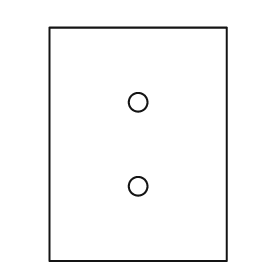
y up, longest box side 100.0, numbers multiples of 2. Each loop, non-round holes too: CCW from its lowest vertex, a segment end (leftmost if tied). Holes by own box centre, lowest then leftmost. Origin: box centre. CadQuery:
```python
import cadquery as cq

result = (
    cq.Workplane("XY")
    .moveTo(-38.0, -50.0)
    .lineTo(38.0, -50.0)
    .lineTo(38.0, 50.0)
    .lineTo(-38.0, 50.0)
    .close()
    .moveTo(0.0, -18.0)
    .circle(4.0)
    .moveTo(0.0, 18.0)
    .circle(4.0)
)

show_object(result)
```